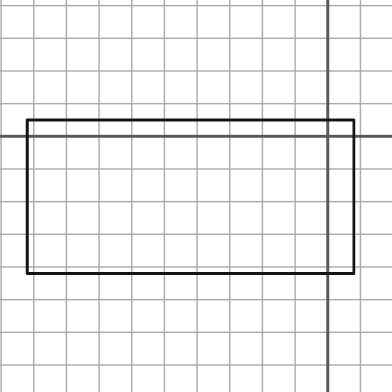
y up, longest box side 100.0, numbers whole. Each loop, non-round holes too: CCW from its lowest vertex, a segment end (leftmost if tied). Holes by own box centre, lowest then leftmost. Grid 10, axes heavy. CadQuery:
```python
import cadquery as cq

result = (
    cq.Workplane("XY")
    .moveTo(-92.0, -42.0)
    .lineTo(8.0, -42.0)
    .lineTo(8.0, 5.0)
    .lineTo(-92.0, 5.0)
    .close()
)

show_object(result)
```